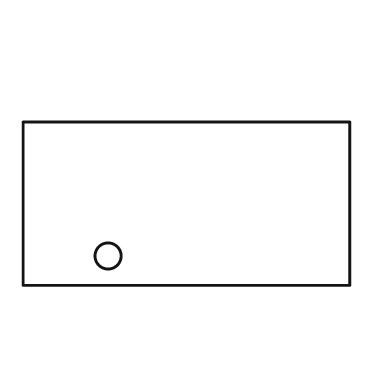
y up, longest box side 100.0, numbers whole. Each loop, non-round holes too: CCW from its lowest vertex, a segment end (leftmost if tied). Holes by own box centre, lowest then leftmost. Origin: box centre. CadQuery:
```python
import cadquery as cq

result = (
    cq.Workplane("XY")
    .moveTo(-50.0, -25.0)
    .lineTo(50.0, -25.0)
    .lineTo(50.0, 25.0)
    .lineTo(-50.0, 25.0)
    .close()
    .moveTo(-24.0, -16.0)
    .circle(4.0)
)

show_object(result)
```